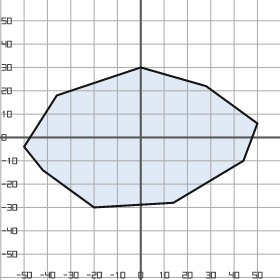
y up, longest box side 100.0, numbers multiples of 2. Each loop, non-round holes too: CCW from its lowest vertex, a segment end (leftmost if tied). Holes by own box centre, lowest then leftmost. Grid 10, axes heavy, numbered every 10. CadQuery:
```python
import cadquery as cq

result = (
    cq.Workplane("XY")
    .moveTo(-20.0, -30.0)
    .lineTo(14.0, -28.0)
    .lineTo(44.0, -10.0)
    .lineTo(50.0, 6.0)
    .lineTo(28.0, 22.0)
    .lineTo(0.0, 30.0)
    .lineTo(-36.0, 18.0)
    .lineTo(-50.0, -4.0)
    .lineTo(-42.0, -14.0)
    .close()
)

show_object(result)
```